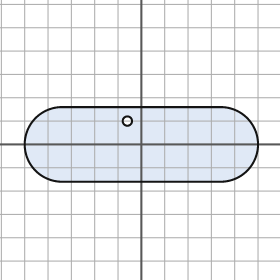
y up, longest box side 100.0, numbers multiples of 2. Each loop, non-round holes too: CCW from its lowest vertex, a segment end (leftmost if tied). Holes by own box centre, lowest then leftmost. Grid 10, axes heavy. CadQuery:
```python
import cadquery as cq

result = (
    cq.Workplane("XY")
    .moveTo(-34.0, -16.0)
    .lineTo(34.0, -16.0)
    .threePointArc((50.0, 0.0), (34.0, 16.0))
    .lineTo(-34.0, 16.0)
    .threePointArc((-50.0, 0.0), (-34.0, -16.0))
    .close()
    .moveTo(-6.0, 10.0)
    .circle(2.0)
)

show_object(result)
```